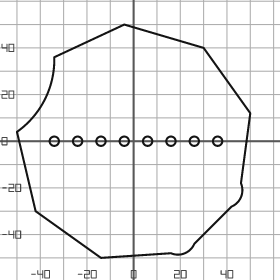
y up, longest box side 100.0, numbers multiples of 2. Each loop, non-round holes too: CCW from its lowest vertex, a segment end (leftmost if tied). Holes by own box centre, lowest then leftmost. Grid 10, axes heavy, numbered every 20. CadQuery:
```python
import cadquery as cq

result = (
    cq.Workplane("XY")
    .moveTo(-14.0, -50.0)
    .lineTo(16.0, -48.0)
    .threePointArc((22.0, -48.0), (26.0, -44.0))
    .lineTo(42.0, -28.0)
    .threePointArc((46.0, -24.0), (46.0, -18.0))
    .lineTo(50.0, 12.0)
    .lineTo(30.0, 40.0)
    .lineTo(-4.0, 50.0)
    .lineTo(-34.0, 36.0)
    .threePointArc((-38.0, 18.0), (-50.0, 4.0))
    .lineTo(-42.0, -30.0)
    .close()
    .moveTo(-34.0, 0.0)
    .circle(2.0)
    .moveTo(-24.0, 0.0)
    .circle(2.0)
    .moveTo(-14.0, 0.0)
    .circle(2.0)
    .moveTo(-4.0, 0.0)
    .circle(2.0)
    .moveTo(6.0, 0.0)
    .circle(2.0)
    .moveTo(16.0, 0.0)
    .circle(2.0)
    .moveTo(26.0, 0.0)
    .circle(2.0)
    .moveTo(36.0, 0.0)
    .circle(2.0)
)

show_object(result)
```